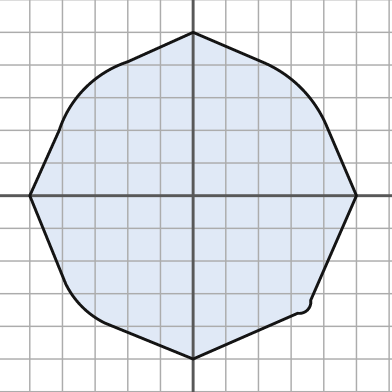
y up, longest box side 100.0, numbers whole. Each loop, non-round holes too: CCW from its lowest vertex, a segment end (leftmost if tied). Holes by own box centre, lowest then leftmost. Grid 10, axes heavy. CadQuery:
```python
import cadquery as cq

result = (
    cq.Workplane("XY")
    .moveTo(0.0, -50.0)
    .lineTo(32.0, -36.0)
    .threePointArc((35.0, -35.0), (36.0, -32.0))
    .lineTo(50.0, 0.0)
    .lineTo(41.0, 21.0)
    .threePointArc((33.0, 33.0), (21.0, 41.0))
    .lineTo(0.0, 50.0)
    .lineTo(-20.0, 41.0)
    .threePointArc((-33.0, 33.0), (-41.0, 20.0))
    .lineTo(-50.0, 0.0)
    .lineTo(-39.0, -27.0)
    .threePointArc((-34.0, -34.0), (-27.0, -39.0))
    .close()
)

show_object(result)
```